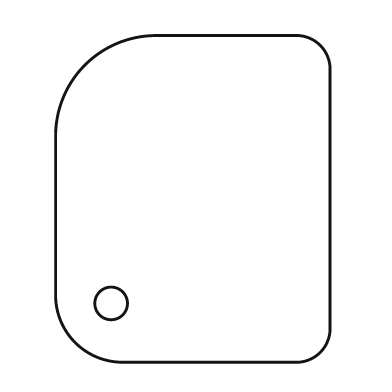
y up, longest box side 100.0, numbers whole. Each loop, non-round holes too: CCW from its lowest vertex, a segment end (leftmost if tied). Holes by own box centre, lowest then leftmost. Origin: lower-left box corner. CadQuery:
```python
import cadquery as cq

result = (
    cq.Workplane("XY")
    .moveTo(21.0, 0.0)
    .lineTo(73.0, 0.0)
    .threePointArc((81.0, 3.0), (84.0, 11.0))
    .lineTo(84.0, 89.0)
    .threePointArc((81.0, 97.0), (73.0, 100.0))
    .lineTo(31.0, 100.0)
    .threePointArc((9.0, 91.0), (0.0, 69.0))
    .lineTo(0.0, 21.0)
    .threePointArc((6.0, 6.0), (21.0, 0.0))
    .close()
    .moveTo(17.0, 18.0)
    .circle(5.0)
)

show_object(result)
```